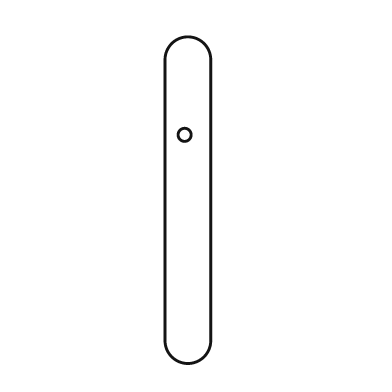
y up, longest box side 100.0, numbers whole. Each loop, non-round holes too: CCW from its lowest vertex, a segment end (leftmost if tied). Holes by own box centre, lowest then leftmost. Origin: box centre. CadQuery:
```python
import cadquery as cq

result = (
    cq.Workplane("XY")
    .moveTo(-7.0, -43.0)
    .threePointArc((0.0, -50.0), (7.0, -43.0))
    .lineTo(7.0, 43.0)
    .threePointArc((0.0, 50.0), (-7.0, 43.0))
    .close()
    .moveTo(-1.0, 20.0)
    .circle(2.0)
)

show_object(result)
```